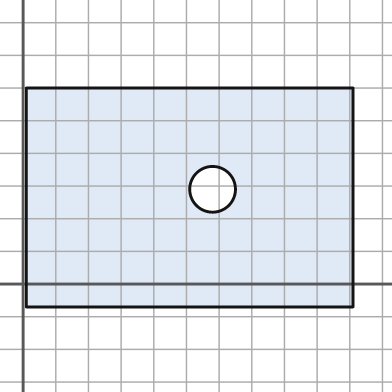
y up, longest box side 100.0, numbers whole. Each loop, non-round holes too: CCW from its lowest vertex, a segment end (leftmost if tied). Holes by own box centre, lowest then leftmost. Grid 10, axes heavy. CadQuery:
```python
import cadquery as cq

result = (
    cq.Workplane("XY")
    .moveTo(1.0, -7.0)
    .lineTo(101.0, -7.0)
    .lineTo(101.0, 60.0)
    .lineTo(1.0, 60.0)
    .close()
    .moveTo(58.0, 29.0)
    .circle(7.0)
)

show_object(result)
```